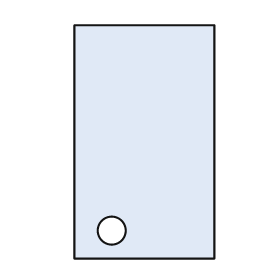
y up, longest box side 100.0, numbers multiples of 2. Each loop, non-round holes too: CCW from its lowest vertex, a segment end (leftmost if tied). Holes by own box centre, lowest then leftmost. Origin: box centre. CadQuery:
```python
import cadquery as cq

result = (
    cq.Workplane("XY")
    .moveTo(-30.0, -50.0)
    .lineTo(30.0, -50.0)
    .lineTo(30.0, 50.0)
    .lineTo(-30.0, 50.0)
    .close()
    .moveTo(-14.0, -38.0)
    .circle(6.0)
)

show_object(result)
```